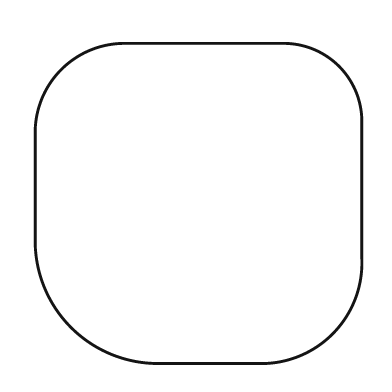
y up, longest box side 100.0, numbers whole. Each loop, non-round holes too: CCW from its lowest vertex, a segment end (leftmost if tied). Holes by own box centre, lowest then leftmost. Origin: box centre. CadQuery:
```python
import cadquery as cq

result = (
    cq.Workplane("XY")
    .moveTo(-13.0, -49.0)
    .lineTo(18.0, -49.0)
    .threePointArc((41.0, -40.0), (50.0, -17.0))
    .lineTo(50.0, 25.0)
    .threePointArc((43.0, 42.0), (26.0, 49.0))
    .lineTo(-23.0, 49.0)
    .threePointArc((-42.0, 41.0), (-50.0, 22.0))
    .lineTo(-50.0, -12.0)
    .threePointArc((-39.0, -38.0), (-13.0, -49.0))
    .close()
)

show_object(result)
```